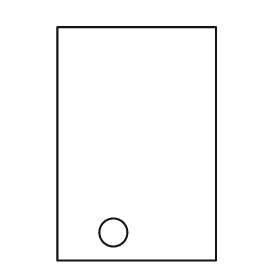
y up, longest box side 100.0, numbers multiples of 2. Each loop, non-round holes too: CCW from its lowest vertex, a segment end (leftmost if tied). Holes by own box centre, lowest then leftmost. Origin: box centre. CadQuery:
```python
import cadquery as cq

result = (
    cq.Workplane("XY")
    .moveTo(-34.0, -50.0)
    .lineTo(34.0, -50.0)
    .lineTo(34.0, 50.0)
    .lineTo(-34.0, 50.0)
    .close()
    .moveTo(-10.0, -38.0)
    .circle(6.0)
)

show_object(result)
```